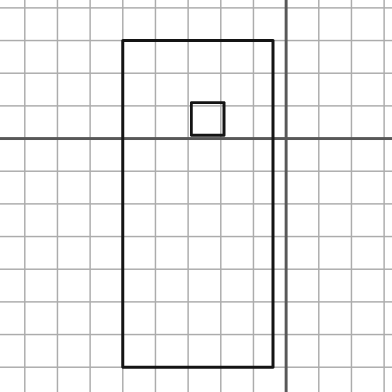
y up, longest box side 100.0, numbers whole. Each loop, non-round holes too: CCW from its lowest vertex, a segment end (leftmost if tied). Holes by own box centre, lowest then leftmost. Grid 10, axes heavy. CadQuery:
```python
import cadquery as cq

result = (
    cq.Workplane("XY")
    .moveTo(-50.0, -70.0)
    .lineTo(-4.0, -70.0)
    .lineTo(-4.0, 30.0)
    .lineTo(-50.0, 30.0)
    .close()
    .moveTo(-29.0, 1.0)
    .lineTo(-19.0, 1.0)
    .lineTo(-19.0, 11.0)
    .lineTo(-29.0, 11.0)
    .close()
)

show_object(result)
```